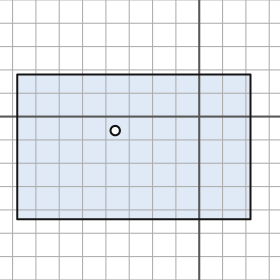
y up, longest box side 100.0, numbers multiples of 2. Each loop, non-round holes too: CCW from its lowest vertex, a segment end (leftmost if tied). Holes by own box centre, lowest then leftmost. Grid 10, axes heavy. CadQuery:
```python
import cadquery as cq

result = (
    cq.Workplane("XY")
    .moveTo(-78.0, -44.0)
    .lineTo(22.0, -44.0)
    .lineTo(22.0, 18.0)
    .lineTo(-78.0, 18.0)
    .close()
    .moveTo(-36.0, -6.0)
    .circle(2.0)
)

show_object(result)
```